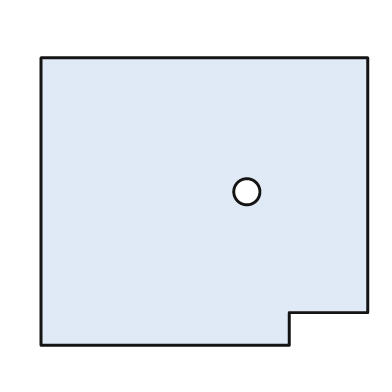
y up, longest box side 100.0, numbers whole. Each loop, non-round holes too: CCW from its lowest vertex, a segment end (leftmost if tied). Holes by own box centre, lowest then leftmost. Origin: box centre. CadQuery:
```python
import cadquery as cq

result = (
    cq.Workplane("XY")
    .moveTo(-50.0, -44.0)
    .lineTo(26.0, -44.0)
    .lineTo(26.0, -34.0)
    .lineTo(50.0, -34.0)
    .lineTo(50.0, 44.0)
    .lineTo(-50.0, 44.0)
    .close()
    .moveTo(13.0, 3.0)
    .circle(4.0)
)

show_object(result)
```